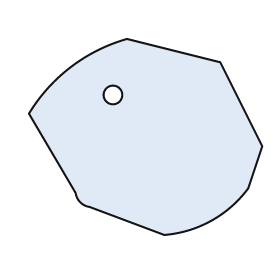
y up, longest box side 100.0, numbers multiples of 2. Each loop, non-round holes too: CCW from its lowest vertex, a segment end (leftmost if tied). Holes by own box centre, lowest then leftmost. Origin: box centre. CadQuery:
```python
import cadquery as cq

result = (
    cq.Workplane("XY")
    .moveTo(8.0, -42.0)
    .threePointArc((28.0, -36.0), (44.0, -22.0))
    .lineTo(50.0, -4.0)
    .lineTo(32.0, 32.0)
    .lineTo(-8.0, 42.0)
    .threePointArc((-32.0, 30.0), (-50.0, 10.0))
    .lineTo(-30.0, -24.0)
    .threePointArc((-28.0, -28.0), (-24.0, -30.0))
    .close()
    .moveTo(-14.0, 18.0)
    .circle(4.0)
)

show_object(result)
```